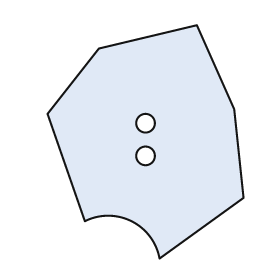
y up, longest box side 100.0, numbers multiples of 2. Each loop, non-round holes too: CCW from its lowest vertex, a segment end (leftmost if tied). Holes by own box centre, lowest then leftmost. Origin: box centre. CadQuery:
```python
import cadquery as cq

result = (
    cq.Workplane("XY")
    .moveTo(6.0, -50.0)
    .lineTo(42.0, -24.0)
    .lineTo(38.0, 14.0)
    .lineTo(22.0, 50.0)
    .lineTo(-20.0, 40.0)
    .lineTo(-42.0, 12.0)
    .lineTo(-26.0, -34.0)
    .threePointArc((-6.0, -34.0), (6.0, -50.0))
    .close()
    .moveTo(0.0, -6.0)
    .circle(4.0)
    .moveTo(0.0, 8.0)
    .circle(4.0)
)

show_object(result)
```